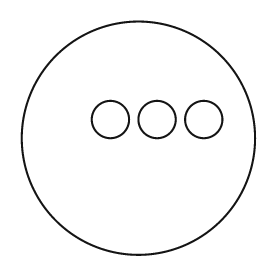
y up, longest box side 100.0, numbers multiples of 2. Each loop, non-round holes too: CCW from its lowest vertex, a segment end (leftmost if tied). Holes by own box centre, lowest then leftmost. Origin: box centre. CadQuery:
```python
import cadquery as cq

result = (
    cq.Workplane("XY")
    .moveTo(0.0, 0.0)
    .circle(50.0)
    .moveTo(-12.0, 8.0)
    .circle(8.0)
    .moveTo(8.0, 8.0)
    .circle(8.0)
    .moveTo(28.0, 8.0)
    .circle(8.0)
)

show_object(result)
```